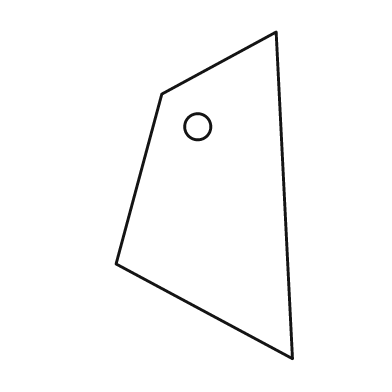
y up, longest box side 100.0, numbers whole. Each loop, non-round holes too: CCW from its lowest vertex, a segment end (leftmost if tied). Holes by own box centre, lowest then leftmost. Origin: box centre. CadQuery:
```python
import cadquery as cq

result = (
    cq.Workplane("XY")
    .moveTo(27.0, -50.0)
    .lineTo(22.0, 50.0)
    .lineTo(-13.0, 31.0)
    .lineTo(-27.0, -21.0)
    .close()
    .moveTo(-2.0, 21.0)
    .circle(4.0)
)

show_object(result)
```